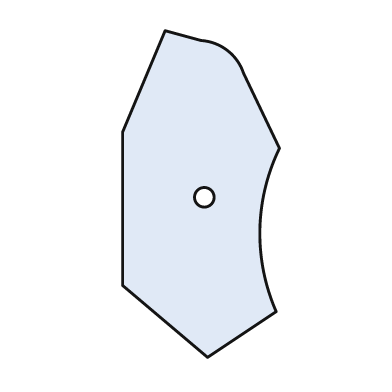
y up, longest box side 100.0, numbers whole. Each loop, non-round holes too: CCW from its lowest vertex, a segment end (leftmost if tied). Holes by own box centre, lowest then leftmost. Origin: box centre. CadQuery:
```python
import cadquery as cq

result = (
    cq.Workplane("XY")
    .moveTo(2.0, -50.0)
    .lineTo(23.0, -36.0)
    .threePointArc((18.0, -11.0), (24.0, 14.0))
    .lineTo(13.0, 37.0)
    .threePointArc((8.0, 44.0), (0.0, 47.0))
    .lineTo(-11.0, 50.0)
    .lineTo(-24.0, 19.0)
    .lineTo(-24.0, -28.0)
    .close()
    .moveTo(1.0, -1.0)
    .circle(3.0)
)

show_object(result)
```